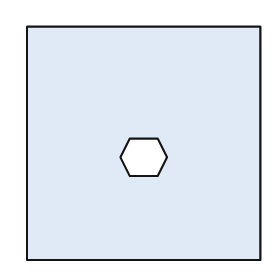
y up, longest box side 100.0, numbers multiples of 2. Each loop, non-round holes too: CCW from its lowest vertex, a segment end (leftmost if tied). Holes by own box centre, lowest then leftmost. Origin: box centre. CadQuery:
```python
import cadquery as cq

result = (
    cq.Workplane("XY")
    .moveTo(-50.0, -50.0)
    .lineTo(50.0, -50.0)
    .lineTo(50.0, 50.0)
    .lineTo(-50.0, 50.0)
    .close()
    .moveTo(-6.0, -14.0)
    .lineTo(6.0, -14.0)
    .lineTo(10.0, -6.0)
    .lineTo(6.0, 2.0)
    .lineTo(-6.0, 2.0)
    .lineTo(-10.0, -6.0)
    .close()
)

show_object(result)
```